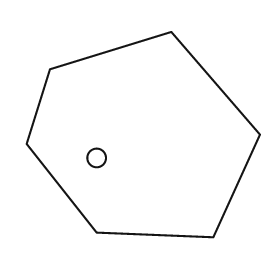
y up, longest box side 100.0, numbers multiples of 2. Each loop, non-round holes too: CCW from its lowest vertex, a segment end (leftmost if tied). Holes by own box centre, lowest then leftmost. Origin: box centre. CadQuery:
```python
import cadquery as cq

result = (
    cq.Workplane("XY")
    .moveTo(30.0, -44.0)
    .lineTo(50.0, 0.0)
    .lineTo(12.0, 44.0)
    .lineTo(-40.0, 28.0)
    .lineTo(-50.0, -4.0)
    .lineTo(-20.0, -42.0)
    .close()
    .moveTo(-20.0, -10.0)
    .circle(4.0)
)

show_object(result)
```